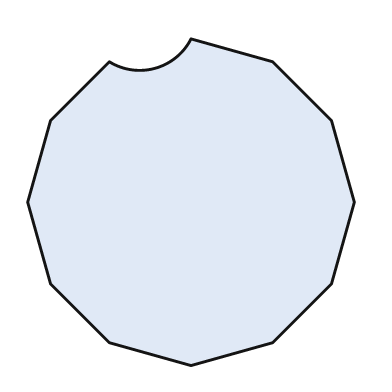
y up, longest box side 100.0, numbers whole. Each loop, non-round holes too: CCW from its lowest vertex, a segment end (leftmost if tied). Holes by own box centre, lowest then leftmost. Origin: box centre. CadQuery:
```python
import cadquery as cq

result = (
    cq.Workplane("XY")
    .moveTo(0.0, -50.0)
    .lineTo(25.0, -43.0)
    .lineTo(43.0, -25.0)
    .lineTo(50.0, 0.0)
    .lineTo(43.0, 25.0)
    .lineTo(25.0, 43.0)
    .lineTo(0.0, 50.0)
    .threePointArc((-11.0, 41.0), (-25.0, 43.0))
    .lineTo(-43.0, 25.0)
    .lineTo(-50.0, 0.0)
    .lineTo(-43.0, -25.0)
    .lineTo(-25.0, -43.0)
    .close()
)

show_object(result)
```